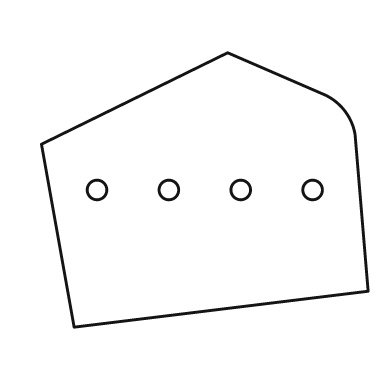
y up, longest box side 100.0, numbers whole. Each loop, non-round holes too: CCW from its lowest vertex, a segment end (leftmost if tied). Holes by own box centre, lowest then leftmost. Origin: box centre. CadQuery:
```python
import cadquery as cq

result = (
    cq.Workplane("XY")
    .moveTo(-40.0, -42.0)
    .lineTo(50.0, -31.0)
    .lineTo(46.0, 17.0)
    .threePointArc((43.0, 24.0), (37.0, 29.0))
    .lineTo(7.0, 42.0)
    .lineTo(-50.0, 14.0)
    .close()
    .moveTo(-33.0, 0.0)
    .circle(3.0)
    .moveTo(-11.0, 0.0)
    .circle(3.0)
    .moveTo(11.0, 0.0)
    .circle(3.0)
    .moveTo(33.0, 0.0)
    .circle(3.0)
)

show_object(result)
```